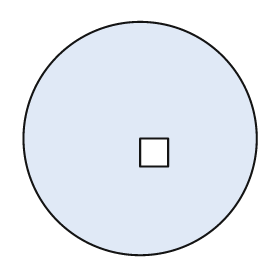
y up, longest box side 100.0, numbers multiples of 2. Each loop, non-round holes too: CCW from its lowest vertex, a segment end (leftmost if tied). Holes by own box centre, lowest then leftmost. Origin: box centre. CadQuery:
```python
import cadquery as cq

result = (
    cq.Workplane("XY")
    .moveTo(0.0, 0.0)
    .circle(50.0)
    .moveTo(0.0, -12.0)
    .lineTo(12.0, -12.0)
    .lineTo(12.0, 0.0)
    .lineTo(0.0, 0.0)
    .close()
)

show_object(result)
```